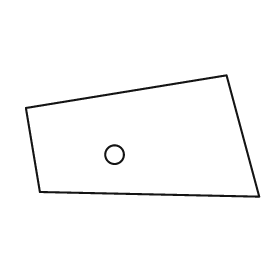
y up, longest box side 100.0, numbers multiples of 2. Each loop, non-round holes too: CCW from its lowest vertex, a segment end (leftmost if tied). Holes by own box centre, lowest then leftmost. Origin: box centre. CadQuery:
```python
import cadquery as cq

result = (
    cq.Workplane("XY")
    .moveTo(50.0, -26.0)
    .lineTo(36.0, 26.0)
    .lineTo(-50.0, 12.0)
    .lineTo(-44.0, -24.0)
    .close()
    .moveTo(-12.0, -8.0)
    .circle(4.0)
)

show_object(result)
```